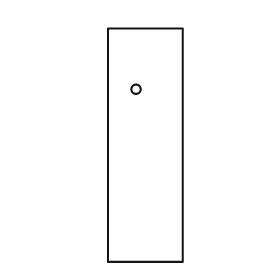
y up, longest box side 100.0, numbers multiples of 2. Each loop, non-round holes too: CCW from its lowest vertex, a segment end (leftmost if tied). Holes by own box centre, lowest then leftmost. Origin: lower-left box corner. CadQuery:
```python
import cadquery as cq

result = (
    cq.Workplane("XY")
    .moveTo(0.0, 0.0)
    .lineTo(32.0, 0.0)
    .lineTo(32.0, 100.0)
    .lineTo(0.0, 100.0)
    .close()
    .moveTo(12.0, 74.0)
    .circle(2.0)
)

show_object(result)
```